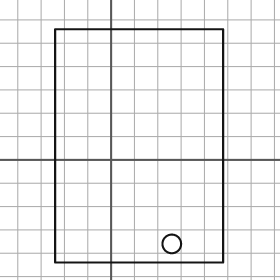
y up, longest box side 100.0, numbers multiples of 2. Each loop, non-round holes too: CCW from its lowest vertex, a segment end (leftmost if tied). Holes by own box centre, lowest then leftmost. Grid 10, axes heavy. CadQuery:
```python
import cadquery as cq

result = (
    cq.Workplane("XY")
    .moveTo(-24.0, -44.0)
    .lineTo(48.0, -44.0)
    .lineTo(48.0, 56.0)
    .lineTo(-24.0, 56.0)
    .close()
    .moveTo(26.0, -36.0)
    .circle(4.0)
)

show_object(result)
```